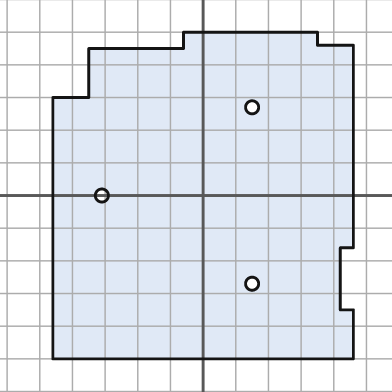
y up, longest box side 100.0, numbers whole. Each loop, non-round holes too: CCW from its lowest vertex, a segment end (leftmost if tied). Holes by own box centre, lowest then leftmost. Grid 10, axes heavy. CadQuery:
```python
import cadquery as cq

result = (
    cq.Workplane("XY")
    .moveTo(-46.0, -50.0)
    .lineTo(46.0, -50.0)
    .lineTo(46.0, -35.0)
    .lineTo(42.0, -35.0)
    .lineTo(42.0, -16.0)
    .lineTo(46.0, -16.0)
    .lineTo(46.0, 46.0)
    .lineTo(35.0, 46.0)
    .lineTo(35.0, 50.0)
    .lineTo(-6.0, 50.0)
    .lineTo(-6.0, 45.0)
    .lineTo(-35.0, 45.0)
    .lineTo(-35.0, 30.0)
    .lineTo(-46.0, 30.0)
    .close()
    .moveTo(15.0, -27.0)
    .circle(2.0)
    .moveTo(-31.0, 0.0)
    .circle(2.0)
    .moveTo(15.0, 27.0)
    .circle(2.0)
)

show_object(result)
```